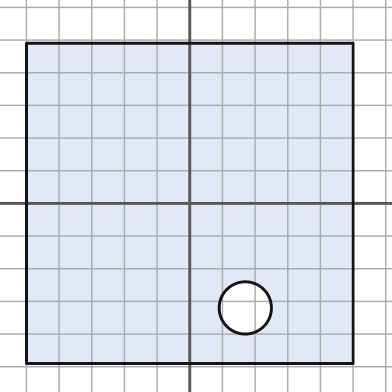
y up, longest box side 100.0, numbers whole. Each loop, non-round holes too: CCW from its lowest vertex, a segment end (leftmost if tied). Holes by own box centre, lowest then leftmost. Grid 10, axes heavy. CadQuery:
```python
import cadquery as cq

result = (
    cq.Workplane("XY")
    .moveTo(-50.0, -49.0)
    .lineTo(50.0, -49.0)
    .lineTo(50.0, 49.0)
    .lineTo(-50.0, 49.0)
    .close()
    .moveTo(17.0, -32.0)
    .circle(8.0)
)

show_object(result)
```